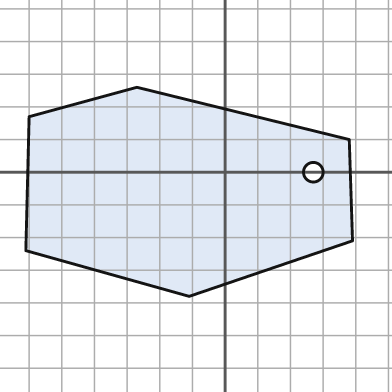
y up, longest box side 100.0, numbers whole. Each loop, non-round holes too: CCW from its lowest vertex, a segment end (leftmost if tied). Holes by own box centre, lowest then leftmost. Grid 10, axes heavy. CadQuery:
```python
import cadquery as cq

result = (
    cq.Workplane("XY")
    .moveTo(-11.0, -38.0)
    .lineTo(39.0, -21.0)
    .lineTo(38.0, 10.0)
    .lineTo(-27.0, 26.0)
    .lineTo(-60.0, 17.0)
    .lineTo(-61.0, -24.0)
    .close()
    .moveTo(27.0, 0.0)
    .circle(3.0)
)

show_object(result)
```